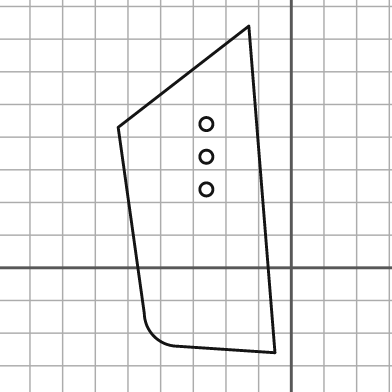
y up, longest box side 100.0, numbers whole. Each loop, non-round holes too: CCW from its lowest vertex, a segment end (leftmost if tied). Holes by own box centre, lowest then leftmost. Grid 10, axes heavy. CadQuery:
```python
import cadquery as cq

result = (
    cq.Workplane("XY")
    .moveTo(-5.0, -26.0)
    .lineTo(-13.0, 74.0)
    .lineTo(-53.0, 43.0)
    .lineTo(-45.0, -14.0)
    .threePointArc((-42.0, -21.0), (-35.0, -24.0))
    .close()
    .moveTo(-26.0, 24.0)
    .circle(2.0)
    .moveTo(-26.0, 34.0)
    .circle(2.0)
    .moveTo(-26.0, 44.0)
    .circle(2.0)
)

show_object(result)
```